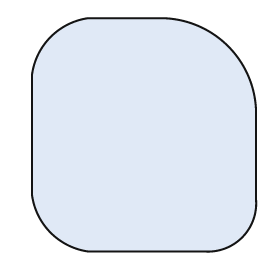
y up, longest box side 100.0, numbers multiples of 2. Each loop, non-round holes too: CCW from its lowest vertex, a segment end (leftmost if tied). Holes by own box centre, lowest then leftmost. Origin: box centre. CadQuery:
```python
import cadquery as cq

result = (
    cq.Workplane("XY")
    .moveTo(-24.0, -50.0)
    .lineTo(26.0, -50.0)
    .threePointArc((42.0, -44.0), (48.0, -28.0))
    .lineTo(48.0, 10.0)
    .threePointArc((36.0, 38.0), (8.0, 50.0))
    .lineTo(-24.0, 50.0)
    .threePointArc((-40.0, 42.0), (-48.0, 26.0))
    .lineTo(-48.0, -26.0)
    .threePointArc((-40.0, -42.0), (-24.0, -50.0))
    .close()
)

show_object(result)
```